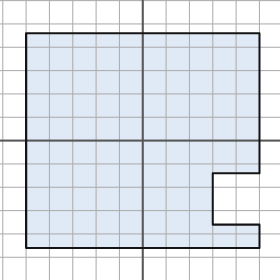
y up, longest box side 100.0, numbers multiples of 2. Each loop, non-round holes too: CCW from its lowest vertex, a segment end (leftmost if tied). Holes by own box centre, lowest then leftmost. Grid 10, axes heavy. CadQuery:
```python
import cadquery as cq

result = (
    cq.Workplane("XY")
    .moveTo(-50.0, -46.0)
    .lineTo(50.0, -46.0)
    .lineTo(50.0, -36.0)
    .lineTo(30.0, -36.0)
    .lineTo(30.0, -14.0)
    .lineTo(50.0, -14.0)
    .lineTo(50.0, 46.0)
    .lineTo(-50.0, 46.0)
    .close()
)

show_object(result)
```